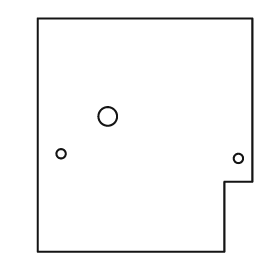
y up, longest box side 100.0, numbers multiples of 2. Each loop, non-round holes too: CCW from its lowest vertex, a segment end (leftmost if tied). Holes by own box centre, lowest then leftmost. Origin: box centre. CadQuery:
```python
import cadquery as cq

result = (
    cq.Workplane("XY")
    .moveTo(-46.0, -50.0)
    .lineTo(34.0, -50.0)
    .lineTo(34.0, -20.0)
    .lineTo(46.0, -20.0)
    .lineTo(46.0, 50.0)
    .lineTo(-46.0, 50.0)
    .close()
    .moveTo(40.0, -10.0)
    .circle(2.0)
    .moveTo(-36.0, -8.0)
    .circle(2.0)
    .moveTo(-16.0, 8.0)
    .circle(4.0)
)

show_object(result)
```